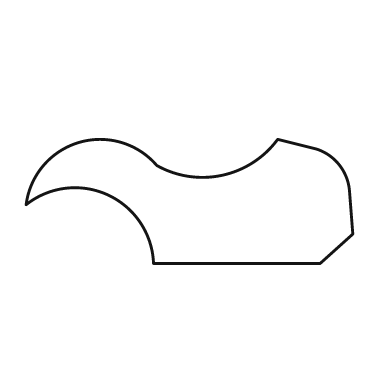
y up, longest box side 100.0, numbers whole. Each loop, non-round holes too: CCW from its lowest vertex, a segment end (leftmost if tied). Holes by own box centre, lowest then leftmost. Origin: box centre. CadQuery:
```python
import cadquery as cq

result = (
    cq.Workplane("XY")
    .moveTo(-11.0, -19.0)
    .lineTo(40.0, -19.0)
    .lineTo(50.0, -10.0)
    .lineTo(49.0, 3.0)
    .threePointArc((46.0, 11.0), (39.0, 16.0))
    .lineTo(27.0, 19.0)
    .threePointArc((10.0, 8.0), (-10.0, 11.0))
    .threePointArc((-34.0, 18.0), (-50.0, -1.0))
    .threePointArc((-25.0, 2.0), (-11.0, -19.0))
    .close()
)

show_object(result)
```